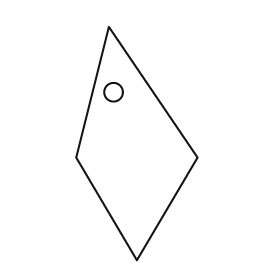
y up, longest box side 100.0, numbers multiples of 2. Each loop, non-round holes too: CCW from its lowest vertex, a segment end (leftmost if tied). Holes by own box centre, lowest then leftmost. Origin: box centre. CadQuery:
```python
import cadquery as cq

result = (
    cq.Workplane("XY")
    .moveTo(0.0, -50.0)
    .lineTo(26.0, -6.0)
    .lineTo(-12.0, 50.0)
    .lineTo(-26.0, -6.0)
    .close()
    .moveTo(-10.0, 22.0)
    .circle(4.0)
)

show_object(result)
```